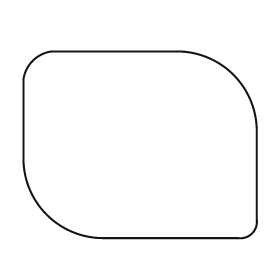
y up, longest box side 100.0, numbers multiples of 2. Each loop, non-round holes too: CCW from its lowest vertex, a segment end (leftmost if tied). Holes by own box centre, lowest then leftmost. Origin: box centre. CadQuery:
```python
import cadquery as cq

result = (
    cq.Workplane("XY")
    .moveTo(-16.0, -40.0)
    .lineTo(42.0, -40.0)
    .threePointArc((48.0, -38.0), (50.0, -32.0))
    .lineTo(50.0, 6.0)
    .threePointArc((40.0, 30.0), (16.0, 40.0))
    .lineTo(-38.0, 40.0)
    .threePointArc((-46.0, 36.0), (-50.0, 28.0))
    .lineTo(-50.0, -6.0)
    .threePointArc((-40.0, -30.0), (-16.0, -40.0))
    .close()
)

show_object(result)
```